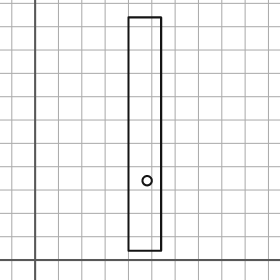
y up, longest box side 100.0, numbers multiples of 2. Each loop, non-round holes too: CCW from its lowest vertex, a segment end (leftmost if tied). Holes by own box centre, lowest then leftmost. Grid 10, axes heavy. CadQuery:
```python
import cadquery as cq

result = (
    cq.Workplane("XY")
    .moveTo(40.0, 4.0)
    .lineTo(54.0, 4.0)
    .lineTo(54.0, 104.0)
    .lineTo(40.0, 104.0)
    .close()
    .moveTo(48.0, 34.0)
    .circle(2.0)
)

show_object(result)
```